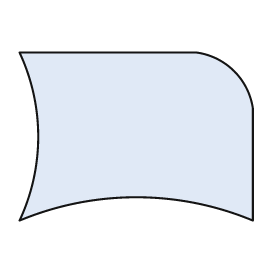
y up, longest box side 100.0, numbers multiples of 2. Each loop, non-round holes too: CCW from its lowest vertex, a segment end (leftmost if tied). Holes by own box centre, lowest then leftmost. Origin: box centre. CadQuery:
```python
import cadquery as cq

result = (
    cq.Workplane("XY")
    .moveTo(-50.0, -36.0)
    .threePointArc((0.0, -26.0), (50.0, -36.0))
    .lineTo(50.0, 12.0)
    .threePointArc((42.0, 28.0), (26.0, 36.0))
    .lineTo(-50.0, 36.0)
    .threePointArc((-42.0, 0.0), (-50.0, -36.0))
    .close()
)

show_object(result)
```